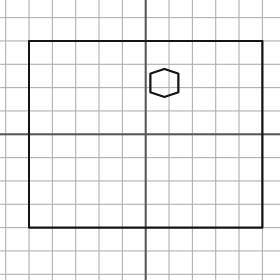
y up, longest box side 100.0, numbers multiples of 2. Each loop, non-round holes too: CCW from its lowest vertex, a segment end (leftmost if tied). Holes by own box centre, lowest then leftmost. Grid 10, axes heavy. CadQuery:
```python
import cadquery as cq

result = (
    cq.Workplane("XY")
    .moveTo(-50.0, -40.0)
    .lineTo(50.0, -40.0)
    .lineTo(50.0, 40.0)
    .lineTo(-50.0, 40.0)
    .close()
    .moveTo(8.0, 16.0)
    .lineTo(14.0, 18.0)
    .lineTo(14.0, 26.0)
    .lineTo(8.0, 28.0)
    .lineTo(2.0, 26.0)
    .lineTo(2.0, 18.0)
    .close()
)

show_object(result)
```